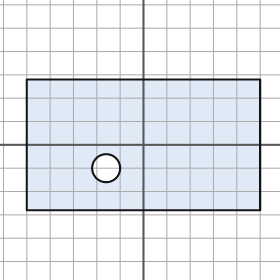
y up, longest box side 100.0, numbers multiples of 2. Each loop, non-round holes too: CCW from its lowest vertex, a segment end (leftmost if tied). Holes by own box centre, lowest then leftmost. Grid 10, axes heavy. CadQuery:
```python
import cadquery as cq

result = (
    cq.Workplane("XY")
    .moveTo(-50.0, -28.0)
    .lineTo(50.0, -28.0)
    .lineTo(50.0, 28.0)
    .lineTo(-50.0, 28.0)
    .close()
    .moveTo(-16.0, -10.0)
    .circle(6.0)
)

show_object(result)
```